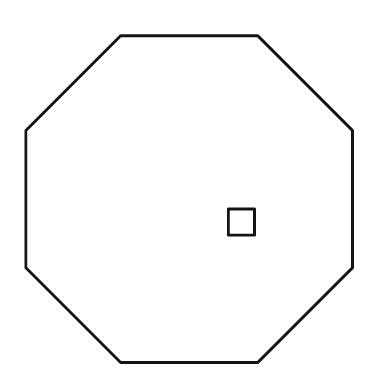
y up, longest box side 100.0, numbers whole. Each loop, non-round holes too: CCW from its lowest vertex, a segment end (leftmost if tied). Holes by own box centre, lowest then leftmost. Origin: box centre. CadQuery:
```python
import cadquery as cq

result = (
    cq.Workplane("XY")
    .moveTo(-21.0, -50.0)
    .lineTo(21.0, -50.0)
    .lineTo(50.0, -21.0)
    .lineTo(50.0, 21.0)
    .lineTo(21.0, 50.0)
    .lineTo(-21.0, 50.0)
    .lineTo(-50.0, 21.0)
    .lineTo(-50.0, -21.0)
    .close()
    .moveTo(12.0, -11.0)
    .lineTo(20.0, -11.0)
    .lineTo(20.0, -3.0)
    .lineTo(12.0, -3.0)
    .close()
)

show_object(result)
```